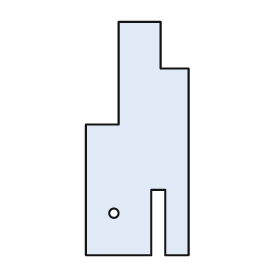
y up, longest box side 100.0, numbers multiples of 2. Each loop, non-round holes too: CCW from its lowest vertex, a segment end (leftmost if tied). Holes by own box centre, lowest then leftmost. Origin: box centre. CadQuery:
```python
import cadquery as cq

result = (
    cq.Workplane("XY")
    .moveTo(-22.0, -50.0)
    .lineTo(6.0, -50.0)
    .lineTo(6.0, -22.0)
    .lineTo(12.0, -22.0)
    .lineTo(12.0, -50.0)
    .lineTo(22.0, -50.0)
    .lineTo(22.0, 30.0)
    .lineTo(10.0, 30.0)
    .lineTo(10.0, 50.0)
    .lineTo(-8.0, 50.0)
    .lineTo(-8.0, 6.0)
    .lineTo(-22.0, 6.0)
    .close()
    .moveTo(-10.0, -32.0)
    .circle(2.0)
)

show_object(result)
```